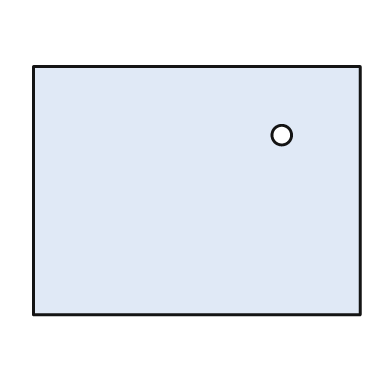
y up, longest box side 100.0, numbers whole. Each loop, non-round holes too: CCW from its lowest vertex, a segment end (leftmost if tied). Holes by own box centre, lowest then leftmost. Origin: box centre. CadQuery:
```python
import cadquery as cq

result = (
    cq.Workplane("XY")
    .moveTo(-50.0, -38.0)
    .lineTo(50.0, -38.0)
    .lineTo(50.0, 38.0)
    .lineTo(-50.0, 38.0)
    .close()
    .moveTo(26.0, 17.0)
    .circle(3.0)
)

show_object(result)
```